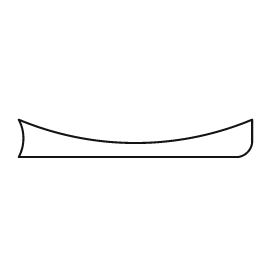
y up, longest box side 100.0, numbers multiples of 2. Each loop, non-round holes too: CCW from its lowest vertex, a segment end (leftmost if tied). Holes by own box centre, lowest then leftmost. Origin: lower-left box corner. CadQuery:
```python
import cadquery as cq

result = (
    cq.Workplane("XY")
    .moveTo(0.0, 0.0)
    .lineTo(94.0, 0.0)
    .threePointArc((98.0, 2.0), (100.0, 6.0))
    .lineTo(100.0, 16.0)
    .threePointArc((50.0, 6.0), (0.0, 16.0))
    .threePointArc((2.0, 8.0), (0.0, 0.0))
    .close()
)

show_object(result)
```